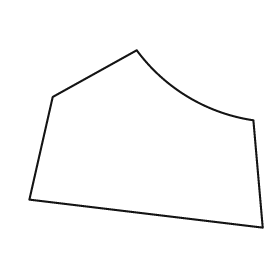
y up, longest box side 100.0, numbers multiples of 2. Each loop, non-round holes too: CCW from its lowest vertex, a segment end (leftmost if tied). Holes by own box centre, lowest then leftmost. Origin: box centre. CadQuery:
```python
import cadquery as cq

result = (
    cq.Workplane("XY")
    .moveTo(50.0, -38.0)
    .lineTo(46.0, 8.0)
    .threePointArc((18.0, 18.0), (-4.0, 38.0))
    .lineTo(-40.0, 18.0)
    .lineTo(-50.0, -26.0)
    .close()
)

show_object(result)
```